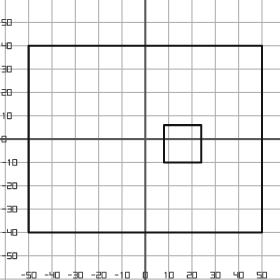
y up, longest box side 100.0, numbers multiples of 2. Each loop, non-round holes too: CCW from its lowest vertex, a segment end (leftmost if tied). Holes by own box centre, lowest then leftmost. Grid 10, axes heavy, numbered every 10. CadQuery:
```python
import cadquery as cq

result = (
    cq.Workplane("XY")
    .moveTo(-50.0, -40.0)
    .lineTo(50.0, -40.0)
    .lineTo(50.0, 40.0)
    .lineTo(-50.0, 40.0)
    .close()
    .moveTo(8.0, -10.0)
    .lineTo(24.0, -10.0)
    .lineTo(24.0, 6.0)
    .lineTo(8.0, 6.0)
    .close()
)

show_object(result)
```